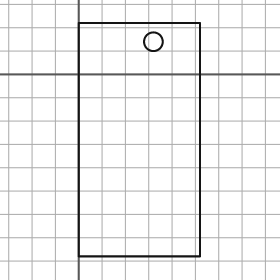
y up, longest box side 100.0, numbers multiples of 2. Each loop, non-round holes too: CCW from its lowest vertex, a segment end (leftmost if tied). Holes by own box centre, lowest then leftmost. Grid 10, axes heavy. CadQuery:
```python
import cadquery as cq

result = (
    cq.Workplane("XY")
    .moveTo(0.0, -78.0)
    .lineTo(52.0, -78.0)
    .lineTo(52.0, 22.0)
    .lineTo(0.0, 22.0)
    .close()
    .moveTo(32.0, 14.0)
    .circle(4.0)
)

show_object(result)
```